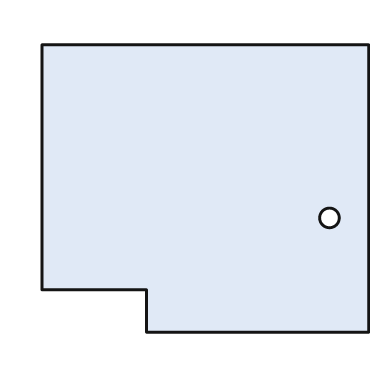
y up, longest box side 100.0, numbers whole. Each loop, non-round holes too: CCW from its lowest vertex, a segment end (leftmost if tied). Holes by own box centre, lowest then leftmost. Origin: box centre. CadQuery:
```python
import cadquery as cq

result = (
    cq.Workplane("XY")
    .moveTo(-18.0, -44.0)
    .lineTo(50.0, -44.0)
    .lineTo(50.0, 44.0)
    .lineTo(-50.0, 44.0)
    .lineTo(-50.0, -31.0)
    .lineTo(-18.0, -31.0)
    .close()
    .moveTo(38.0, -9.0)
    .circle(3.0)
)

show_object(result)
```